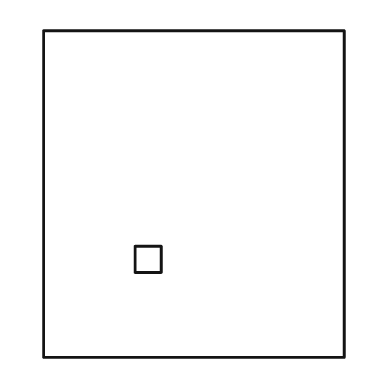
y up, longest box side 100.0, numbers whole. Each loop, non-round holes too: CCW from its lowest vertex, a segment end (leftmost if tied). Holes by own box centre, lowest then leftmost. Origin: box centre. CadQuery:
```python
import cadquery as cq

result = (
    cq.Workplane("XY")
    .moveTo(-46.0, -50.0)
    .lineTo(46.0, -50.0)
    .lineTo(46.0, 50.0)
    .lineTo(-46.0, 50.0)
    .close()
    .moveTo(-18.0, -24.0)
    .lineTo(-10.0, -24.0)
    .lineTo(-10.0, -16.0)
    .lineTo(-18.0, -16.0)
    .close()
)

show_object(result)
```